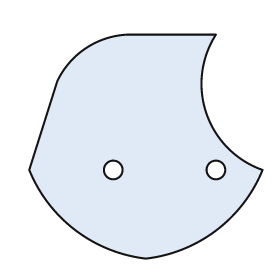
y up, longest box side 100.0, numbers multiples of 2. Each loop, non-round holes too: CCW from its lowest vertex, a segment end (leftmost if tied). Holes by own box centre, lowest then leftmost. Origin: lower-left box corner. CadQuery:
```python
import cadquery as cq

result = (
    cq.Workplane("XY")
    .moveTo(50.0, 0.0)
    .threePointArc((80.0, 12.0), (100.0, 38.0))
    .threePointArc((76.0, 62.0), (80.0, 96.0))
    .lineTo(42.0, 96.0)
    .threePointArc((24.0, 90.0), (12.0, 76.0))
    .lineTo(0.0, 38.0)
    .threePointArc((20.0, 12.0), (50.0, 0.0))
    .close()
    .moveTo(36.0, 38.0)
    .circle(4.0)
    .moveTo(80.0, 38.0)
    .circle(4.0)
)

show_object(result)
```